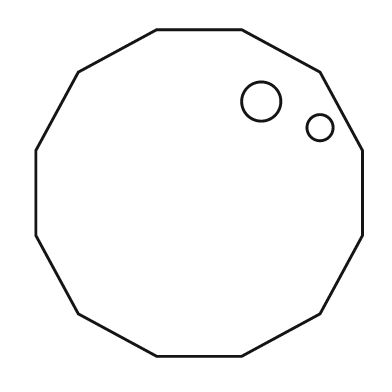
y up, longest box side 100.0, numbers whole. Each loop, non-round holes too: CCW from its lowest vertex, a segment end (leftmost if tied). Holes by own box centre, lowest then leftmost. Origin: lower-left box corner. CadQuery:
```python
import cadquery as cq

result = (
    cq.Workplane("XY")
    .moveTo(37.0, 0.0)
    .lineTo(63.0, 0.0)
    .lineTo(87.0, 13.0)
    .lineTo(100.0, 37.0)
    .lineTo(100.0, 63.0)
    .lineTo(87.0, 87.0)
    .lineTo(63.0, 100.0)
    .lineTo(37.0, 100.0)
    .lineTo(13.0, 87.0)
    .lineTo(0.0, 63.0)
    .lineTo(0.0, 37.0)
    .lineTo(13.0, 13.0)
    .close()
    .moveTo(87.0, 70.0)
    .circle(4.0)
    .moveTo(69.0, 78.0)
    .circle(6.0)
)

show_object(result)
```